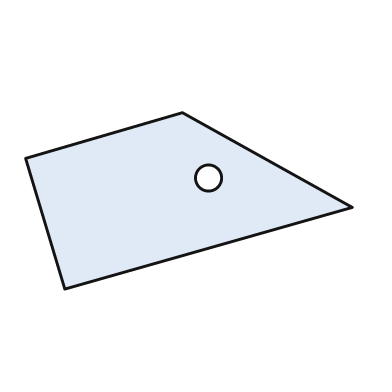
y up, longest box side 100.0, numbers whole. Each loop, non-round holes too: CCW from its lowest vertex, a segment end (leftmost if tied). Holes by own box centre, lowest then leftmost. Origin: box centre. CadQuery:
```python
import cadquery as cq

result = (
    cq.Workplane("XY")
    .moveTo(-38.0, -27.0)
    .lineTo(50.0, -2.0)
    .lineTo(-2.0, 27.0)
    .lineTo(-50.0, 13.0)
    .close()
    .moveTo(6.0, 7.0)
    .circle(4.0)
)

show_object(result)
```